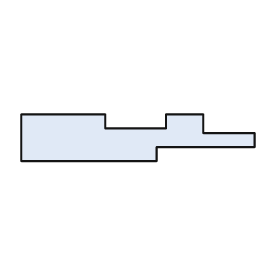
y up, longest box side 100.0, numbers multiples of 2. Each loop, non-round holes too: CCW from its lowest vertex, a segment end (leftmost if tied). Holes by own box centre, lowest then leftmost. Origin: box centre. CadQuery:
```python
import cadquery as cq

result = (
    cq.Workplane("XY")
    .moveTo(-50.0, -10.0)
    .lineTo(8.0, -10.0)
    .lineTo(8.0, -4.0)
    .lineTo(50.0, -4.0)
    .lineTo(50.0, 2.0)
    .lineTo(28.0, 2.0)
    .lineTo(28.0, 10.0)
    .lineTo(12.0, 10.0)
    .lineTo(12.0, 4.0)
    .lineTo(-14.0, 4.0)
    .lineTo(-14.0, 10.0)
    .lineTo(-50.0, 10.0)
    .close()
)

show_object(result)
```